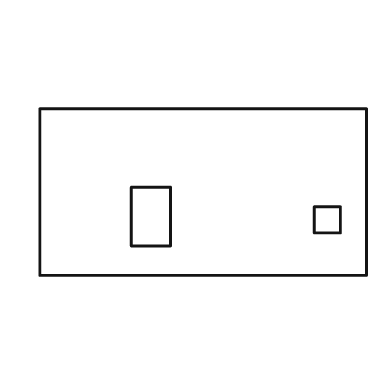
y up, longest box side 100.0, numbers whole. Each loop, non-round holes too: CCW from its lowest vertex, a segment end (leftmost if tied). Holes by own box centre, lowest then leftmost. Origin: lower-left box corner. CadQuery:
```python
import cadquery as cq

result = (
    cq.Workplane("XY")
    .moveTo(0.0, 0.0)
    .lineTo(100.0, 0.0)
    .lineTo(100.0, 51.0)
    .lineTo(0.0, 51.0)
    .close()
    .moveTo(84.0, 13.0)
    .lineTo(92.0, 13.0)
    .lineTo(92.0, 21.0)
    .lineTo(84.0, 21.0)
    .close()
    .moveTo(28.0, 9.0)
    .lineTo(40.0, 9.0)
    .lineTo(40.0, 27.0)
    .lineTo(28.0, 27.0)
    .close()
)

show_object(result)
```